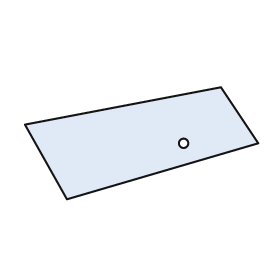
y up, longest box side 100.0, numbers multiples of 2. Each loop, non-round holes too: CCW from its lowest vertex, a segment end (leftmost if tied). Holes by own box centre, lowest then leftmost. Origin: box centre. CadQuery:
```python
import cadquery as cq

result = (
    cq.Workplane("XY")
    .moveTo(-32.0, -24.0)
    .lineTo(50.0, 0.0)
    .lineTo(34.0, 24.0)
    .lineTo(-50.0, 8.0)
    .close()
    .moveTo(18.0, 0.0)
    .circle(2.0)
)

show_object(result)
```